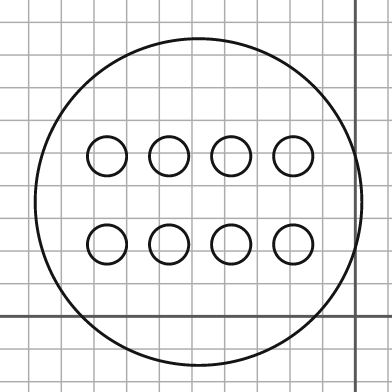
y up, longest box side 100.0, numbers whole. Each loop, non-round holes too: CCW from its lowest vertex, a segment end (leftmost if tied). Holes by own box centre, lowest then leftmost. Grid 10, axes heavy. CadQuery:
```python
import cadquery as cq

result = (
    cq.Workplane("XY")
    .moveTo(-48.0, 35.0)
    .circle(50.0)
    .moveTo(-76.0, 22.0)
    .circle(6.0)
    .moveTo(-57.0, 22.0)
    .circle(6.0)
    .moveTo(-38.0, 22.0)
    .circle(6.0)
    .moveTo(-19.0, 22.0)
    .circle(6.0)
    .moveTo(-76.0, 49.0)
    .circle(6.0)
    .moveTo(-57.0, 49.0)
    .circle(6.0)
    .moveTo(-38.0, 49.0)
    .circle(6.0)
    .moveTo(-19.0, 49.0)
    .circle(6.0)
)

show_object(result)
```